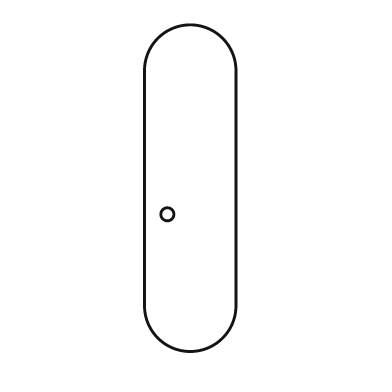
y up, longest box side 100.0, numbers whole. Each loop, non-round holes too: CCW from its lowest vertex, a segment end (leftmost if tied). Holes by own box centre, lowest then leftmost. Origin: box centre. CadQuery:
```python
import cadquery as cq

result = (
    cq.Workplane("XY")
    .moveTo(-14.0, -36.0)
    .threePointArc((0.0, -50.0), (14.0, -36.0))
    .lineTo(14.0, 36.0)
    .threePointArc((0.0, 50.0), (-14.0, 36.0))
    .close()
    .moveTo(-7.0, -8.0)
    .circle(2.0)
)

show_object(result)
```